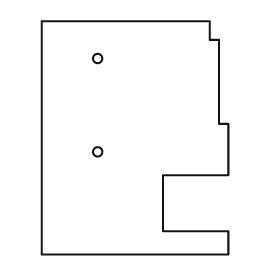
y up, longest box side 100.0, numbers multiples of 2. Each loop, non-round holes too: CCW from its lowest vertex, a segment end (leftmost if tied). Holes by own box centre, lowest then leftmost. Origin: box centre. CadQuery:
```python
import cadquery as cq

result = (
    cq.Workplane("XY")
    .moveTo(-40.0, -50.0)
    .lineTo(40.0, -50.0)
    .lineTo(40.0, -40.0)
    .lineTo(12.0, -40.0)
    .lineTo(12.0, -16.0)
    .lineTo(40.0, -16.0)
    .lineTo(40.0, 6.0)
    .lineTo(36.0, 6.0)
    .lineTo(36.0, 42.0)
    .lineTo(32.0, 42.0)
    .lineTo(32.0, 50.0)
    .lineTo(-40.0, 50.0)
    .close()
    .moveTo(-16.0, -6.0)
    .circle(2.0)
    .moveTo(-16.0, 34.0)
    .circle(2.0)
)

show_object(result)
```